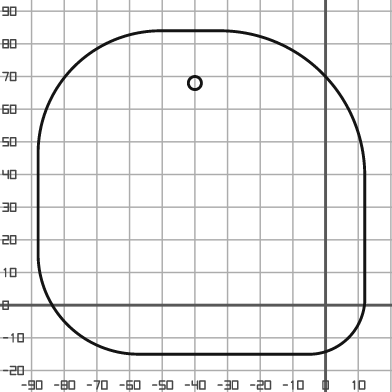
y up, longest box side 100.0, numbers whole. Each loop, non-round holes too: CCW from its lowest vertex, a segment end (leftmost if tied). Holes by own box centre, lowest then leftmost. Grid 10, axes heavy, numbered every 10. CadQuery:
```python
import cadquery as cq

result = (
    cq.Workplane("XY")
    .moveTo(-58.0, -15.0)
    .lineTo(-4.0, -15.0)
    .threePointArc((7.0, -10.0), (12.0, 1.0))
    .lineTo(12.0, 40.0)
    .threePointArc((-1.0, 71.0), (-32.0, 84.0))
    .lineTo(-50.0, 84.0)
    .threePointArc((-77.0, 73.0), (-88.0, 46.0))
    .lineTo(-88.0, 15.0)
    .threePointArc((-79.0, -6.0), (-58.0, -15.0))
    .close()
    .moveTo(-40.0, 68.0)
    .circle(2.0)
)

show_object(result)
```